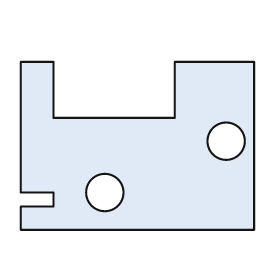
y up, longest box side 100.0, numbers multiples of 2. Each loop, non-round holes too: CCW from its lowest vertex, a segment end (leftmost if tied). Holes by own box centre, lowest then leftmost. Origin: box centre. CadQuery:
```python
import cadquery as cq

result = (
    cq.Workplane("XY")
    .moveTo(-50.0, -36.0)
    .lineTo(50.0, -36.0)
    .lineTo(50.0, 36.0)
    .lineTo(16.0, 36.0)
    .lineTo(16.0, 12.0)
    .lineTo(-36.0, 12.0)
    .lineTo(-36.0, 36.0)
    .lineTo(-50.0, 36.0)
    .lineTo(-50.0, -20.0)
    .lineTo(-36.0, -20.0)
    .lineTo(-36.0, -26.0)
    .lineTo(-50.0, -26.0)
    .close()
    .moveTo(-14.0, -20.0)
    .circle(8.0)
    .moveTo(38.0, 2.0)
    .circle(8.0)
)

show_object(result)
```